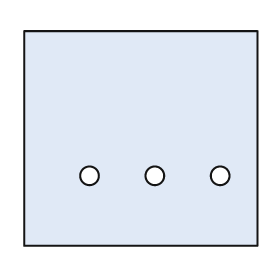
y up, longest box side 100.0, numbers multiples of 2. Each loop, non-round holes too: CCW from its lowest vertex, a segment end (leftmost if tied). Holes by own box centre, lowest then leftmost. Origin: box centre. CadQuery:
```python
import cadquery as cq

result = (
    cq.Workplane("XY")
    .moveTo(-50.0, -46.0)
    .lineTo(50.0, -46.0)
    .lineTo(50.0, 46.0)
    .lineTo(-50.0, 46.0)
    .close()
    .moveTo(-22.0, -16.0)
    .circle(4.0)
    .moveTo(6.0, -16.0)
    .circle(4.0)
    .moveTo(34.0, -16.0)
    .circle(4.0)
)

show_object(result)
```